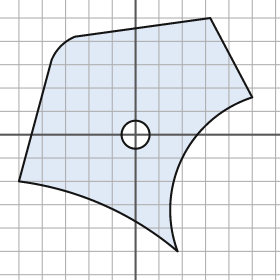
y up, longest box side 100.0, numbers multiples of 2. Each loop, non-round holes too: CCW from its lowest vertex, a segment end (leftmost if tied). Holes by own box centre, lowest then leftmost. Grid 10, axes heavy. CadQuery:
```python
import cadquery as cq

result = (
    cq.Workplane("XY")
    .moveTo(18.0, -50.0)
    .threePointArc((20.0, -10.0), (50.0, 16.0))
    .lineTo(32.0, 50.0)
    .lineTo(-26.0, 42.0)
    .threePointArc((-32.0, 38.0), (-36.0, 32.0))
    .lineTo(-50.0, -20.0)
    .threePointArc((-14.0, -30.0), (18.0, -50.0))
    .close()
    .moveTo(0.0, 0.0)
    .circle(6.0)
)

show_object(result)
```